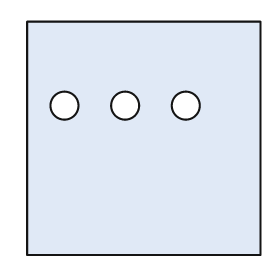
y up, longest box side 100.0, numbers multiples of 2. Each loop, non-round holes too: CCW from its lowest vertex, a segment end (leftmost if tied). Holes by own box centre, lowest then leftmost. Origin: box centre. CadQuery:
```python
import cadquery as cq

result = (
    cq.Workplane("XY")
    .moveTo(-50.0, -50.0)
    .lineTo(50.0, -50.0)
    .lineTo(50.0, 50.0)
    .lineTo(-50.0, 50.0)
    .close()
    .moveTo(-34.0, 14.0)
    .circle(6.0)
    .moveTo(-8.0, 14.0)
    .circle(6.0)
    .moveTo(18.0, 14.0)
    .circle(6.0)
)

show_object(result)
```